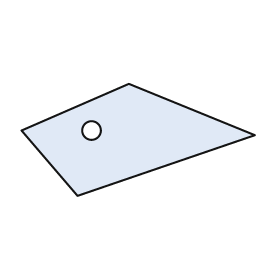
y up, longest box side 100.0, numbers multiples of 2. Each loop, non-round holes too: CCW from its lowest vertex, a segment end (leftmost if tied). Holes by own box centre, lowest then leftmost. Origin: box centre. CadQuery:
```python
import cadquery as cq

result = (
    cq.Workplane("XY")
    .moveTo(-26.0, -24.0)
    .lineTo(50.0, 2.0)
    .lineTo(-4.0, 24.0)
    .lineTo(-50.0, 4.0)
    .close()
    .moveTo(-20.0, 4.0)
    .circle(4.0)
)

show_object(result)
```